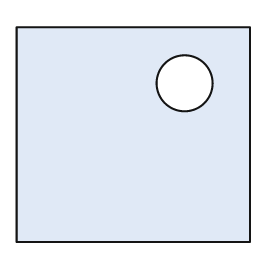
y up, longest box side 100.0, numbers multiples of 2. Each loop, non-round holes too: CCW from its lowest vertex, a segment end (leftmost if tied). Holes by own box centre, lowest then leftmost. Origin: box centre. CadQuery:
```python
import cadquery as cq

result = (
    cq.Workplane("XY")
    .moveTo(-50.0, -46.0)
    .lineTo(50.0, -46.0)
    .lineTo(50.0, 46.0)
    .lineTo(-50.0, 46.0)
    .close()
    .moveTo(22.0, 22.0)
    .circle(12.0)
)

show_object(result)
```